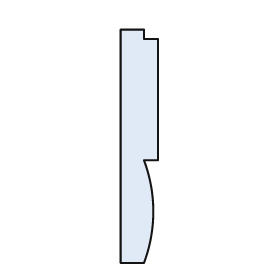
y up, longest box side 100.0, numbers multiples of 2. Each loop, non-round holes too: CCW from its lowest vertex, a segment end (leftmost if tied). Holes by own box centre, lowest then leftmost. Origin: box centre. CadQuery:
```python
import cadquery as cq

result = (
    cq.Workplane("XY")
    .moveTo(-8.0, -50.0)
    .lineTo(2.0, -50.0)
    .threePointArc((6.0, -28.0), (2.0, -6.0))
    .lineTo(8.0, -6.0)
    .lineTo(8.0, 46.0)
    .lineTo(2.0, 46.0)
    .lineTo(2.0, 50.0)
    .lineTo(-8.0, 50.0)
    .close()
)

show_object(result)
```